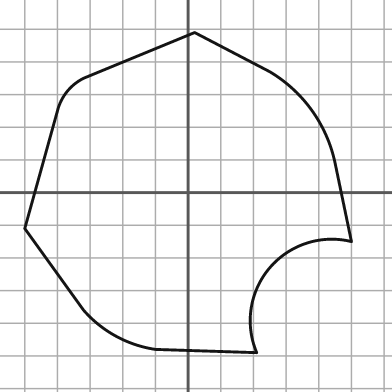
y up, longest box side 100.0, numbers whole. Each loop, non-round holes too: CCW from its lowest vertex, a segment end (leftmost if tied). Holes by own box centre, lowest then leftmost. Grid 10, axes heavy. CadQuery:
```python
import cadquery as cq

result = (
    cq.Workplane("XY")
    .moveTo(21.0, -49.0)
    .threePointArc((25.0, -23.0), (50.0, -15.0))
    .lineTo(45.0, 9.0)
    .threePointArc((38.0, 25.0), (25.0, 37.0))
    .lineTo(2.0, 49.0)
    .lineTo(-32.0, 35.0)
    .threePointArc((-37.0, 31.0), (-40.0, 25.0))
    .lineTo(-50.0, -11.0)
    .lineTo(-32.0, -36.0)
    .threePointArc((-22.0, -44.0), (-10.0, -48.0))
    .close()
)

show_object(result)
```